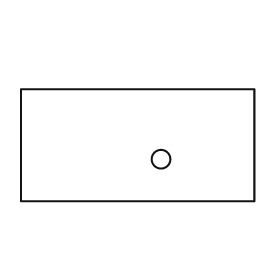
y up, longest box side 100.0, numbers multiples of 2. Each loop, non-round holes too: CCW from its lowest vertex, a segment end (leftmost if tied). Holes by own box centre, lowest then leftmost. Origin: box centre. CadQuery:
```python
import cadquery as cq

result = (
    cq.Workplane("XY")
    .moveTo(-50.0, -24.0)
    .lineTo(50.0, -24.0)
    .lineTo(50.0, 24.0)
    .lineTo(-50.0, 24.0)
    .close()
    .moveTo(10.0, -6.0)
    .circle(4.0)
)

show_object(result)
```